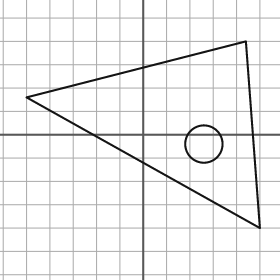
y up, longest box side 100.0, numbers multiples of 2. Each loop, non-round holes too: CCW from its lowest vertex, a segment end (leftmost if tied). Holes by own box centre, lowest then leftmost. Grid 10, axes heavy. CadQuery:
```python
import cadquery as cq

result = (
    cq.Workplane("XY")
    .moveTo(50.0, -40.0)
    .lineTo(44.0, 40.0)
    .lineTo(-50.0, 16.0)
    .close()
    .moveTo(26.0, -4.0)
    .circle(8.0)
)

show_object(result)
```